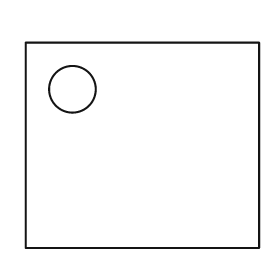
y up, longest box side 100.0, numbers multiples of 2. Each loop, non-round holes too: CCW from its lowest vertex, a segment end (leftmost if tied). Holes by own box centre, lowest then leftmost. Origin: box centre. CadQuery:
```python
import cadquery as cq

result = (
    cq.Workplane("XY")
    .moveTo(-50.0, -44.0)
    .lineTo(50.0, -44.0)
    .lineTo(50.0, 44.0)
    .lineTo(-50.0, 44.0)
    .close()
    .moveTo(-30.0, 24.0)
    .circle(10.0)
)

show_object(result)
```